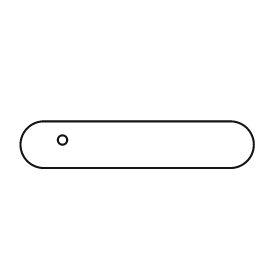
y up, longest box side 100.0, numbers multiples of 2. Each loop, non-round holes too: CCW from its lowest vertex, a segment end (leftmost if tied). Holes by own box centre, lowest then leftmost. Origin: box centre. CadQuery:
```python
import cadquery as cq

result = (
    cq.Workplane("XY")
    .moveTo(-40.0, -10.0)
    .lineTo(40.0, -10.0)
    .threePointArc((50.0, 0.0), (40.0, 10.0))
    .lineTo(-40.0, 10.0)
    .threePointArc((-50.0, 0.0), (-40.0, -10.0))
    .close()
    .moveTo(-32.0, 2.0)
    .circle(2.0)
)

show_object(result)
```